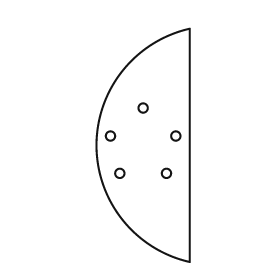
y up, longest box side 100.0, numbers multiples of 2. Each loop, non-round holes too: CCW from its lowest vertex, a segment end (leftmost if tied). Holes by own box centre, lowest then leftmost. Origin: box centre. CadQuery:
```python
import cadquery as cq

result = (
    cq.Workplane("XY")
    .moveTo(20.0, -50.0)
    .lineTo(20.0, 50.0)
    .threePointArc((-20.0, 0.0), (20.0, -50.0))
    .close()
    .moveTo(-10.0, -12.0)
    .circle(2.0)
    .moveTo(10.0, -12.0)
    .circle(2.0)
    .moveTo(-14.0, 4.0)
    .circle(2.0)
    .moveTo(14.0, 4.0)
    .circle(2.0)
    .moveTo(0.0, 16.0)
    .circle(2.0)
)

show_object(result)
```